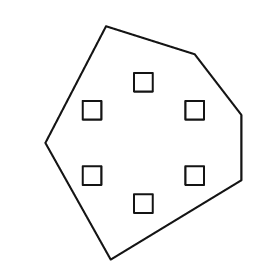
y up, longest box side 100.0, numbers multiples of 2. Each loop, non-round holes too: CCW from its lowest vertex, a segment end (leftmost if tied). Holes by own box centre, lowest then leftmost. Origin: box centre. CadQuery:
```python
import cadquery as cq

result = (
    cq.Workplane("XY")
    .moveTo(-14.0, -50.0)
    .lineTo(42.0, -16.0)
    .lineTo(42.0, 12.0)
    .lineTo(22.0, 38.0)
    .lineTo(-16.0, 50.0)
    .lineTo(-42.0, 0.0)
    .close()
    .moveTo(-4.0, -30.0)
    .lineTo(4.0, -30.0)
    .lineTo(4.0, -22.0)
    .lineTo(-4.0, -22.0)
    .close()
    .moveTo(-26.0, -18.0)
    .lineTo(-18.0, -18.0)
    .lineTo(-18.0, -10.0)
    .lineTo(-26.0, -10.0)
    .close()
    .moveTo(18.0, -18.0)
    .lineTo(26.0, -18.0)
    .lineTo(26.0, -10.0)
    .lineTo(18.0, -10.0)
    .close()
    .moveTo(-26.0, 10.0)
    .lineTo(-18.0, 10.0)
    .lineTo(-18.0, 18.0)
    .lineTo(-26.0, 18.0)
    .close()
    .moveTo(18.0, 10.0)
    .lineTo(26.0, 10.0)
    .lineTo(26.0, 18.0)
    .lineTo(18.0, 18.0)
    .close()
    .moveTo(-4.0, 22.0)
    .lineTo(4.0, 22.0)
    .lineTo(4.0, 30.0)
    .lineTo(-4.0, 30.0)
    .close()
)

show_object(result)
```